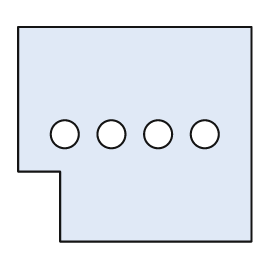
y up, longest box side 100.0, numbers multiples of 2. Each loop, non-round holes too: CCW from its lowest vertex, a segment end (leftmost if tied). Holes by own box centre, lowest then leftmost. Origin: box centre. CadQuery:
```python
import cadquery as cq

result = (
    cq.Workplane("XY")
    .moveTo(-32.0, -46.0)
    .lineTo(50.0, -46.0)
    .lineTo(50.0, 46.0)
    .lineTo(-50.0, 46.0)
    .lineTo(-50.0, -16.0)
    .lineTo(-32.0, -16.0)
    .close()
    .moveTo(-30.0, 0.0)
    .circle(6.0)
    .moveTo(-10.0, 0.0)
    .circle(6.0)
    .moveTo(10.0, 0.0)
    .circle(6.0)
    .moveTo(30.0, 0.0)
    .circle(6.0)
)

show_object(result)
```